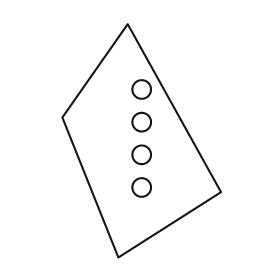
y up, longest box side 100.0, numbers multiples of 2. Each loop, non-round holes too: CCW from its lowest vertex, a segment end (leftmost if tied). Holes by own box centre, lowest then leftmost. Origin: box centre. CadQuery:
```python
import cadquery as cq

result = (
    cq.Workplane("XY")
    .moveTo(-10.0, -50.0)
    .lineTo(34.0, -22.0)
    .lineTo(-6.0, 50.0)
    .lineTo(-34.0, 10.0)
    .close()
    .moveTo(0.0, -20.0)
    .circle(4.0)
    .moveTo(0.0, -6.0)
    .circle(4.0)
    .moveTo(0.0, 8.0)
    .circle(4.0)
    .moveTo(0.0, 22.0)
    .circle(4.0)
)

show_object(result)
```